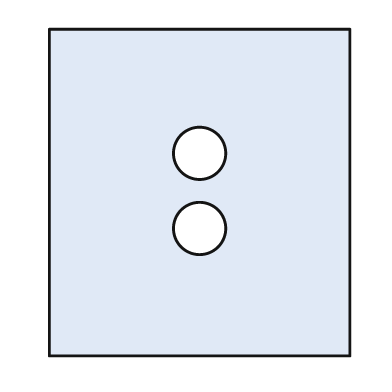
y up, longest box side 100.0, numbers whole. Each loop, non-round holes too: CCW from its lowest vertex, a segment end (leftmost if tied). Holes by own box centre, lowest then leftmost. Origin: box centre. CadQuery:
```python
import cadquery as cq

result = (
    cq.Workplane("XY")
    .moveTo(-46.0, -50.0)
    .lineTo(46.0, -50.0)
    .lineTo(46.0, 50.0)
    .lineTo(-46.0, 50.0)
    .close()
    .moveTo(0.0, -11.0)
    .circle(8.0)
    .moveTo(0.0, 12.0)
    .circle(8.0)
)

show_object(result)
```